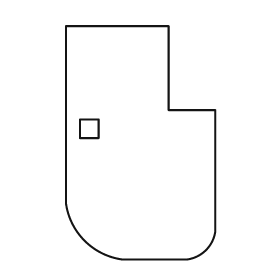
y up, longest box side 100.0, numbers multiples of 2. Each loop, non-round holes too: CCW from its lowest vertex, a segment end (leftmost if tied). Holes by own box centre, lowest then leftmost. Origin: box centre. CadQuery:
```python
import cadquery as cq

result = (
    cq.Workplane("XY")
    .moveTo(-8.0, -50.0)
    .lineTo(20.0, -50.0)
    .threePointArc((28.0, -46.0), (32.0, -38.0))
    .lineTo(32.0, 14.0)
    .lineTo(12.0, 14.0)
    .lineTo(12.0, 50.0)
    .lineTo(-32.0, 50.0)
    .lineTo(-32.0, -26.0)
    .threePointArc((-24.0, -42.0), (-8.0, -50.0))
    .close()
    .moveTo(-26.0, 2.0)
    .lineTo(-18.0, 2.0)
    .lineTo(-18.0, 10.0)
    .lineTo(-26.0, 10.0)
    .close()
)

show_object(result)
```